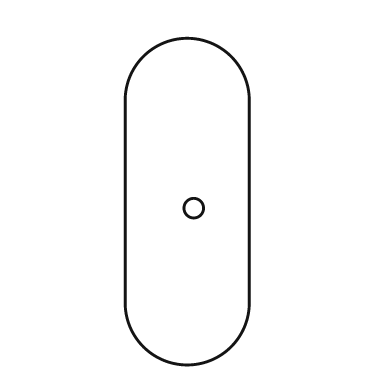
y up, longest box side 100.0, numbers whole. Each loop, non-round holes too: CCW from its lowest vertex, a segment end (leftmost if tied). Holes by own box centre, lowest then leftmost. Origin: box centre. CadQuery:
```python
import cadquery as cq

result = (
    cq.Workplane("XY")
    .moveTo(-19.0, -31.0)
    .threePointArc((0.0, -50.0), (19.0, -31.0))
    .lineTo(19.0, 31.0)
    .threePointArc((0.0, 50.0), (-19.0, 31.0))
    .close()
    .moveTo(2.0, -2.0)
    .circle(3.0)
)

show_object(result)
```